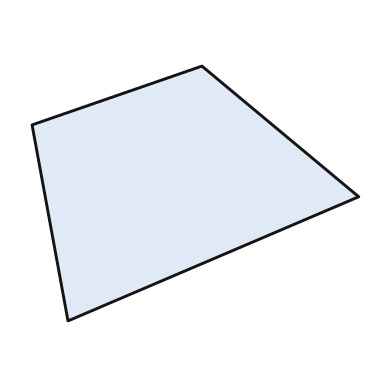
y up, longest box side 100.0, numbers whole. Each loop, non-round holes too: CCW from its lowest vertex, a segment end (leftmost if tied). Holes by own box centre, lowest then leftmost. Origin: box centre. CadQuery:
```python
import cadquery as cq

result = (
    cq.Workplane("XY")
    .moveTo(-39.0, -39.0)
    .lineTo(50.0, -1.0)
    .lineTo(2.0, 39.0)
    .lineTo(-50.0, 21.0)
    .close()
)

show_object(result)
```